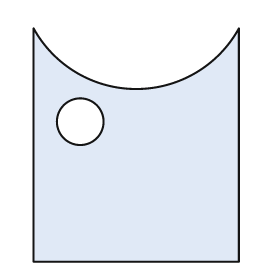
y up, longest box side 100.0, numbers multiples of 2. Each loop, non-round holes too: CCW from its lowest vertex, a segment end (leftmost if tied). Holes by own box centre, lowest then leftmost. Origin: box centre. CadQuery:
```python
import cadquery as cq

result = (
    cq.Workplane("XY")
    .moveTo(-44.0, -50.0)
    .lineTo(44.0, -50.0)
    .lineTo(44.0, 50.0)
    .threePointArc((0.0, 24.0), (-44.0, 50.0))
    .close()
    .moveTo(-24.0, 10.0)
    .circle(10.0)
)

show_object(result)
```